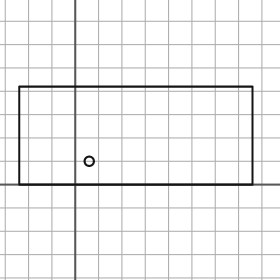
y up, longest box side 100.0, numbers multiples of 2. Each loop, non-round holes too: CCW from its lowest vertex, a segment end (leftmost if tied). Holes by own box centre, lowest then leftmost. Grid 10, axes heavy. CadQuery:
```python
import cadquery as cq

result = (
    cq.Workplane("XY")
    .moveTo(-24.0, 0.0)
    .lineTo(76.0, 0.0)
    .lineTo(76.0, 42.0)
    .lineTo(-24.0, 42.0)
    .close()
    .moveTo(6.0, 10.0)
    .circle(2.0)
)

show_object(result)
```